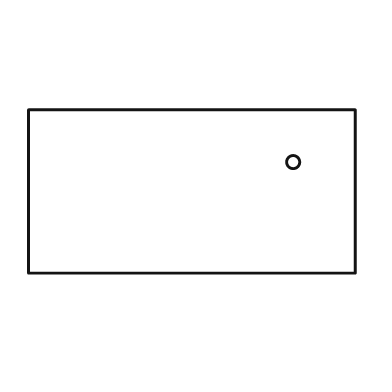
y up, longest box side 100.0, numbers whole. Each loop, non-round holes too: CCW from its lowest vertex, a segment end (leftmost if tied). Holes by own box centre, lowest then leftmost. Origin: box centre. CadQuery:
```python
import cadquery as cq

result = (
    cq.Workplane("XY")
    .moveTo(-50.0, -25.0)
    .lineTo(50.0, -25.0)
    .lineTo(50.0, 25.0)
    .lineTo(-50.0, 25.0)
    .close()
    .moveTo(31.0, 9.0)
    .circle(2.0)
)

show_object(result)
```